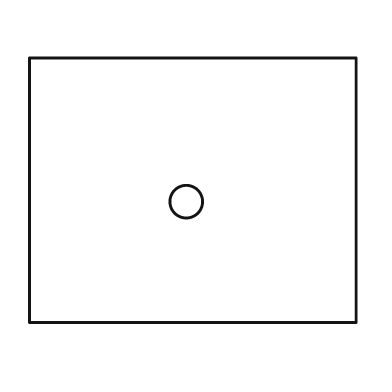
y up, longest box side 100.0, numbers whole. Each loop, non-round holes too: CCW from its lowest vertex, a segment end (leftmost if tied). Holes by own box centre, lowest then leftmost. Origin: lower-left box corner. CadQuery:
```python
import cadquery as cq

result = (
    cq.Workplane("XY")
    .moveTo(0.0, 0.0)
    .lineTo(100.0, 0.0)
    .lineTo(100.0, 81.0)
    .lineTo(0.0, 81.0)
    .close()
    .moveTo(48.0, 37.0)
    .circle(5.0)
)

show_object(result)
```